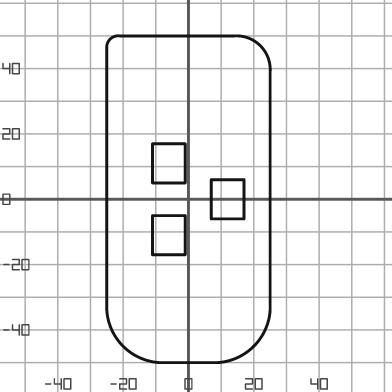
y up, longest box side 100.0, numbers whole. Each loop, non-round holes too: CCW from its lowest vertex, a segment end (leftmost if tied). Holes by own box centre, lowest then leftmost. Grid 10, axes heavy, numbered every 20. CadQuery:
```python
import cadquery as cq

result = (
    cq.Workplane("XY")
    .moveTo(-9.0, -50.0)
    .lineTo(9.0, -50.0)
    .threePointArc((20.0, -45.0), (25.0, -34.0))
    .lineTo(25.0, 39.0)
    .threePointArc((22.0, 47.0), (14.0, 50.0))
    .lineTo(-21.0, 50.0)
    .threePointArc((-24.0, 49.0), (-25.0, 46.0))
    .lineTo(-25.0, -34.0)
    .threePointArc((-20.0, -45.0), (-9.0, -50.0))
    .close()
    .moveTo(-11.0, -17.0)
    .lineTo(-1.0, -17.0)
    .lineTo(-1.0, -5.0)
    .lineTo(-11.0, -5.0)
    .close()
    .moveTo(7.0, -6.0)
    .lineTo(17.0, -6.0)
    .lineTo(17.0, 6.0)
    .lineTo(7.0, 6.0)
    .close()
    .moveTo(-11.0, 5.0)
    .lineTo(-1.0, 5.0)
    .lineTo(-1.0, 17.0)
    .lineTo(-11.0, 17.0)
    .close()
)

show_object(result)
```